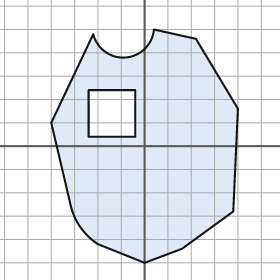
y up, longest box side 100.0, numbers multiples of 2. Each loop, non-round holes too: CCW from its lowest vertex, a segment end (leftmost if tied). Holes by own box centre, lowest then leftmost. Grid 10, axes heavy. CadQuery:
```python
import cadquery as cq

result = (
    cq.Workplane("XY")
    .moveTo(0.0, -50.0)
    .lineTo(16.0, -44.0)
    .lineTo(38.0, -28.0)
    .lineTo(40.0, 16.0)
    .lineTo(22.0, 46.0)
    .lineTo(4.0, 50.0)
    .threePointArc((-8.0, 38.0), (-22.0, 48.0))
    .lineTo(-40.0, 10.0)
    .lineTo(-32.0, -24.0)
    .threePointArc((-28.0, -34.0), (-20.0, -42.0))
    .close()
    .moveTo(-24.0, 4.0)
    .lineTo(-4.0, 4.0)
    .lineTo(-4.0, 24.0)
    .lineTo(-24.0, 24.0)
    .close()
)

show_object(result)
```